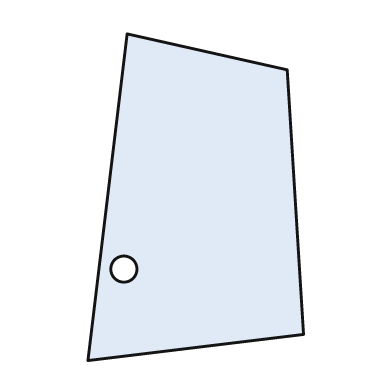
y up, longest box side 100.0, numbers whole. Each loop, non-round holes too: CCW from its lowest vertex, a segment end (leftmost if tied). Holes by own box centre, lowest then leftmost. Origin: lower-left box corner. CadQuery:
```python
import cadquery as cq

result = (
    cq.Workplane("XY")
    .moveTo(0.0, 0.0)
    .lineTo(66.0, 8.0)
    .lineTo(61.0, 89.0)
    .lineTo(12.0, 100.0)
    .close()
    .moveTo(11.0, 28.0)
    .circle(4.0)
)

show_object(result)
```